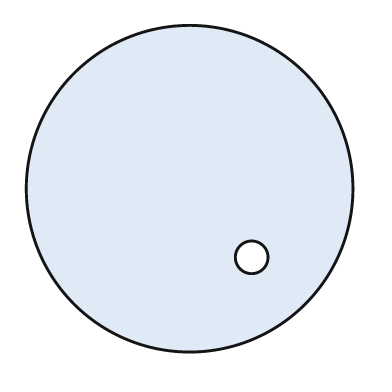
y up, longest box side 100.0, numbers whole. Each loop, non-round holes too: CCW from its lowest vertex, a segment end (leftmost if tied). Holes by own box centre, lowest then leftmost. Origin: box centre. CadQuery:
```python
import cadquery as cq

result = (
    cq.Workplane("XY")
    .moveTo(0.0, 0.0)
    .circle(50.0)
    .moveTo(19.0, -21.0)
    .circle(5.0)
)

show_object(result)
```